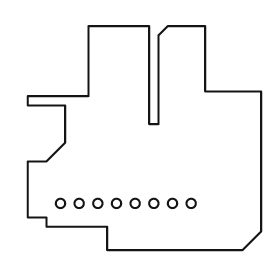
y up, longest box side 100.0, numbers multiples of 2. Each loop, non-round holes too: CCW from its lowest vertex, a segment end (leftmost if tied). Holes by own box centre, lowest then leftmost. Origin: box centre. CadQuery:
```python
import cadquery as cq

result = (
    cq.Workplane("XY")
    .moveTo(-16.0, -48.0)
    .lineTo(42.0, -48.0)
    .lineTo(50.0, -40.0)
    .lineTo(50.0, 20.0)
    .lineTo(26.0, 20.0)
    .lineTo(26.0, 48.0)
    .lineTo(10.0, 48.0)
    .lineTo(6.0, 44.0)
    .lineTo(6.0, 6.0)
    .lineTo(2.0, 6.0)
    .lineTo(2.0, 48.0)
    .lineTo(-24.0, 48.0)
    .lineTo(-24.0, 18.0)
    .lineTo(-50.0, 18.0)
    .lineTo(-50.0, 14.0)
    .lineTo(-34.0, 14.0)
    .lineTo(-34.0, -2.0)
    .lineTo(-42.0, -10.0)
    .lineTo(-50.0, -10.0)
    .lineTo(-50.0, -34.0)
    .lineTo(-42.0, -34.0)
    .lineTo(-42.0, -38.0)
    .lineTo(-16.0, -38.0)
    .close()
    .moveTo(-36.0, -28.0)
    .circle(2.0)
    .moveTo(-28.0, -28.0)
    .circle(2.0)
    .moveTo(-20.0, -28.0)
    .circle(2.0)
    .moveTo(-12.0, -28.0)
    .circle(2.0)
    .moveTo(-4.0, -28.0)
    .circle(2.0)
    .moveTo(4.0, -28.0)
    .circle(2.0)
    .moveTo(12.0, -28.0)
    .circle(2.0)
    .moveTo(20.0, -28.0)
    .circle(2.0)
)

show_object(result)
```